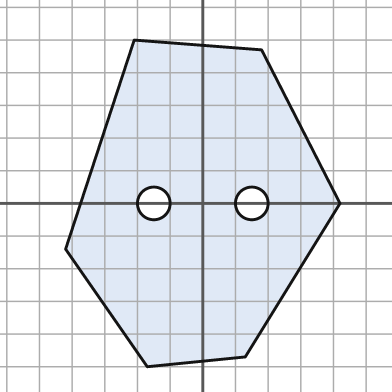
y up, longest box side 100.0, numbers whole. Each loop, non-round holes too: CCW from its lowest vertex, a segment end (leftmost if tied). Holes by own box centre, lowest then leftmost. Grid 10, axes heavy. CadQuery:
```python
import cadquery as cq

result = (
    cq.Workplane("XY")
    .moveTo(-17.0, -50.0)
    .lineTo(13.0, -47.0)
    .lineTo(42.0, 0.0)
    .lineTo(18.0, 47.0)
    .lineTo(-21.0, 50.0)
    .lineTo(-42.0, -14.0)
    .close()
    .moveTo(-15.0, 0.0)
    .circle(5.0)
    .moveTo(15.0, 0.0)
    .circle(5.0)
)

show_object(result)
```